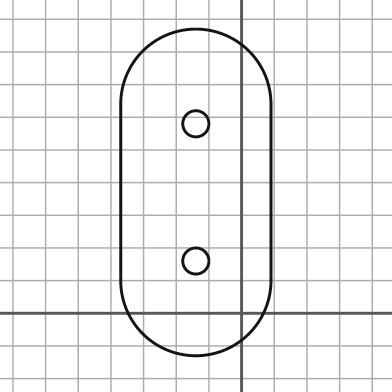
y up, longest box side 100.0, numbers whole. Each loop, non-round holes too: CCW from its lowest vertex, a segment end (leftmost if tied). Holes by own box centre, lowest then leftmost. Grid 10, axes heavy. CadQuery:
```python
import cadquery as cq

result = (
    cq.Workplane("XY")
    .moveTo(-37.0, 10.0)
    .threePointArc((-14.0, -13.0), (9.0, 10.0))
    .lineTo(9.0, 64.0)
    .threePointArc((-14.0, 87.0), (-37.0, 64.0))
    .close()
    .moveTo(-14.0, 16.0)
    .circle(4.0)
    .moveTo(-14.0, 58.0)
    .circle(4.0)
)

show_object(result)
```